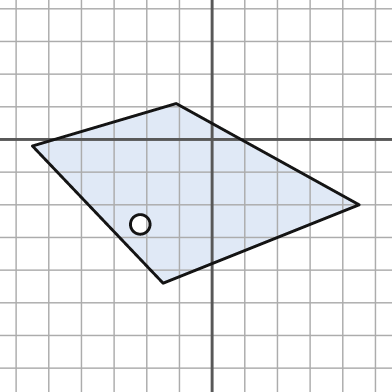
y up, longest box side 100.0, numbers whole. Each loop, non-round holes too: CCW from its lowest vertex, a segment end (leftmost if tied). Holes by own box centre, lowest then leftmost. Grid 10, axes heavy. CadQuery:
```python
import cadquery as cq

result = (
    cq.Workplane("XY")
    .moveTo(-15.0, -44.0)
    .lineTo(45.0, -20.0)
    .lineTo(-11.0, 11.0)
    .lineTo(-55.0, -2.0)
    .close()
    .moveTo(-22.0, -26.0)
    .circle(3.0)
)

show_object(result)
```